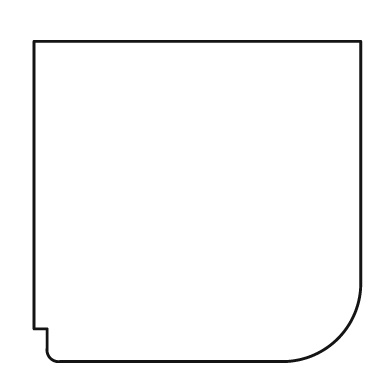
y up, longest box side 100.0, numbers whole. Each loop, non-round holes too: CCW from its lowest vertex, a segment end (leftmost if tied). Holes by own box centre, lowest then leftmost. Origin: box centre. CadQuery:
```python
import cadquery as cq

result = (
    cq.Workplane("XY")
    .moveTo(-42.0, -49.0)
    .lineTo(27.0, -49.0)
    .threePointArc((43.0, -42.0), (50.0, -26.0))
    .lineTo(50.0, 49.0)
    .lineTo(-50.0, 49.0)
    .lineTo(-50.0, -39.0)
    .lineTo(-46.0, -39.0)
    .lineTo(-46.0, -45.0)
    .threePointArc((-45.0, -48.0), (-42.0, -49.0))
    .close()
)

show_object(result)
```